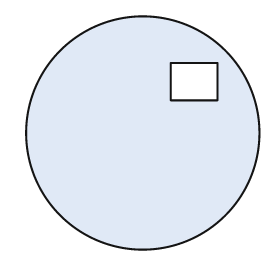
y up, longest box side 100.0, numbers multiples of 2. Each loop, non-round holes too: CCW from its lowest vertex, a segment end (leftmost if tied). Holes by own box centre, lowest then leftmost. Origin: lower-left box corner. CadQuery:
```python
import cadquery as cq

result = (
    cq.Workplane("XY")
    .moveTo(50.0, 50.0)
    .circle(50.0)
    .moveTo(62.0, 64.0)
    .lineTo(82.0, 64.0)
    .lineTo(82.0, 80.0)
    .lineTo(62.0, 80.0)
    .close()
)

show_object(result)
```